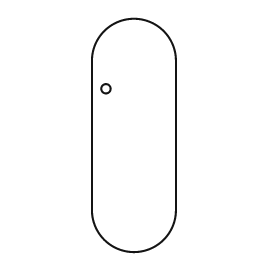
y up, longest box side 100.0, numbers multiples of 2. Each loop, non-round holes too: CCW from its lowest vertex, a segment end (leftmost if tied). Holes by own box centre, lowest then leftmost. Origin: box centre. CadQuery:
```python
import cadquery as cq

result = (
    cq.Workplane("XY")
    .moveTo(-18.0, -32.0)
    .threePointArc((0.0, -50.0), (18.0, -32.0))
    .lineTo(18.0, 32.0)
    .threePointArc((0.0, 50.0), (-18.0, 32.0))
    .close()
    .moveTo(-12.0, 20.0)
    .circle(2.0)
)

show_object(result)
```